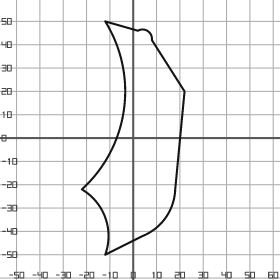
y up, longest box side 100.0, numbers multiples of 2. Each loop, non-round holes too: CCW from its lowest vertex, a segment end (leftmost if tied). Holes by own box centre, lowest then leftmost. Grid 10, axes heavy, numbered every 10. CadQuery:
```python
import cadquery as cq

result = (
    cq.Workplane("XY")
    .moveTo(-12.0, -50.0)
    .lineTo(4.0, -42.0)
    .threePointArc((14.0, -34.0), (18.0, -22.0))
    .lineTo(22.0, 20.0)
    .lineTo(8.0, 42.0)
    .threePointArc((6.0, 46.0), (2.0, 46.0))
    .lineTo(-12.0, 50.0)
    .threePointArc((-4.0, 12.0), (-22.0, -22.0))
    .threePointArc((-12.0, -34.0), (-12.0, -50.0))
    .close()
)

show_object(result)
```